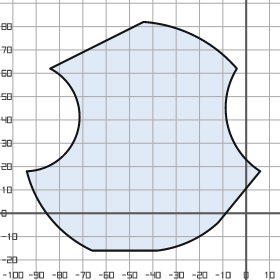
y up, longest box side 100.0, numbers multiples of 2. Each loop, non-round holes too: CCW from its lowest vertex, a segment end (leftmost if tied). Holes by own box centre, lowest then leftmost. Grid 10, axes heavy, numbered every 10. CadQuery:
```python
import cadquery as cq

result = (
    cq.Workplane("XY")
    .moveTo(-66.0, -16.0)
    .lineTo(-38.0, -16.0)
    .threePointArc((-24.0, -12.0), (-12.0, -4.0))
    .lineTo(6.0, 18.0)
    .threePointArc((-8.0, 38.0), (-4.0, 62.0))
    .threePointArc((-22.0, 76.0), (-44.0, 82.0))
    .lineTo(-84.0, 62.0)
    .threePointArc((-72.0, 36.0), (-94.0, 18.0))
    .threePointArc((-84.0, -2.0), (-66.0, -16.0))
    .close()
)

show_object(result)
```